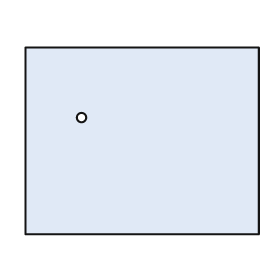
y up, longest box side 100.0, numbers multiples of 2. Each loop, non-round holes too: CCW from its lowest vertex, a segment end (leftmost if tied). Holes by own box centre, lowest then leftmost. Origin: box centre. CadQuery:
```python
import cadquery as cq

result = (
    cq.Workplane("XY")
    .moveTo(-50.0, -40.0)
    .lineTo(50.0, -40.0)
    .lineTo(50.0, 40.0)
    .lineTo(-50.0, 40.0)
    .close()
    .moveTo(-26.0, 10.0)
    .circle(2.0)
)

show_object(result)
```